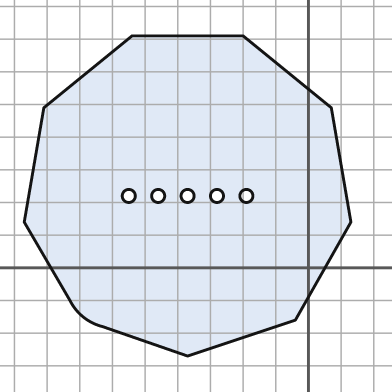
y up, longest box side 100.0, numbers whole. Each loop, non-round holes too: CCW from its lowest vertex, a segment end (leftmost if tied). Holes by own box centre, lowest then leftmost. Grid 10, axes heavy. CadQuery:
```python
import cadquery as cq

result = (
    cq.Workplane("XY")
    .moveTo(-37.0, -27.0)
    .lineTo(-4.0, -16.0)
    .lineTo(13.0, 14.0)
    .lineTo(7.0, 49.0)
    .lineTo(-20.0, 71.0)
    .lineTo(-54.0, 71.0)
    .lineTo(-81.0, 49.0)
    .lineTo(-87.0, 14.0)
    .lineTo(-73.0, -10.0)
    .threePointArc((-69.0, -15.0), (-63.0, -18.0))
    .close()
    .moveTo(-55.0, 22.0)
    .circle(2.0)
    .moveTo(-46.0, 22.0)
    .circle(2.0)
    .moveTo(-37.0, 22.0)
    .circle(2.0)
    .moveTo(-28.0, 22.0)
    .circle(2.0)
    .moveTo(-19.0, 22.0)
    .circle(2.0)
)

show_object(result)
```